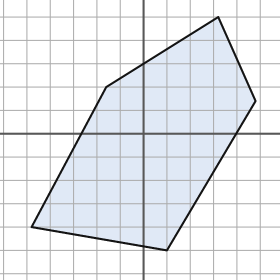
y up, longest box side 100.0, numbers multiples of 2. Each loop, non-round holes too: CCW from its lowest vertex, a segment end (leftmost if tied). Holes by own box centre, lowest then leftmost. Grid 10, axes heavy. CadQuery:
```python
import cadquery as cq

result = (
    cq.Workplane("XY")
    .moveTo(10.0, -50.0)
    .lineTo(48.0, 14.0)
    .lineTo(32.0, 50.0)
    .lineTo(-16.0, 20.0)
    .lineTo(-48.0, -40.0)
    .close()
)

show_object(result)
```